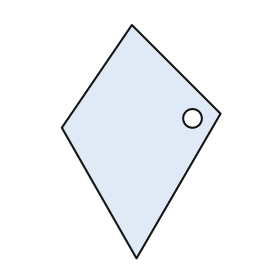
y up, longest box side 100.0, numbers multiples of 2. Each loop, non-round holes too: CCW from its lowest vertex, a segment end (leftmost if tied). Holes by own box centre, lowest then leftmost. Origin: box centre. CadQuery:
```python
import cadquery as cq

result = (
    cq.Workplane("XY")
    .moveTo(-2.0, -50.0)
    .lineTo(34.0, 12.0)
    .lineTo(-4.0, 50.0)
    .lineTo(-34.0, 6.0)
    .close()
    .moveTo(22.0, 10.0)
    .circle(4.0)
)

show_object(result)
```